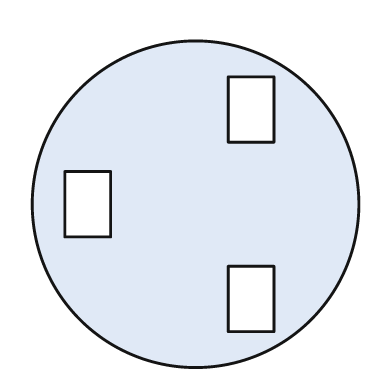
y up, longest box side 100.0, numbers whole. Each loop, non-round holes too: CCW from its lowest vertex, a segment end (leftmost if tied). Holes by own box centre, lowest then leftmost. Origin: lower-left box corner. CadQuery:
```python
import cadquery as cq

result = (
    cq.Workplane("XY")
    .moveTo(50.0, 50.0)
    .circle(50.0)
    .moveTo(60.0, 11.0)
    .lineTo(74.0, 11.0)
    .lineTo(74.0, 31.0)
    .lineTo(60.0, 31.0)
    .close()
    .moveTo(10.0, 40.0)
    .lineTo(24.0, 40.0)
    .lineTo(24.0, 60.0)
    .lineTo(10.0, 60.0)
    .close()
    .moveTo(60.0, 69.0)
    .lineTo(74.0, 69.0)
    .lineTo(74.0, 89.0)
    .lineTo(60.0, 89.0)
    .close()
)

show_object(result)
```